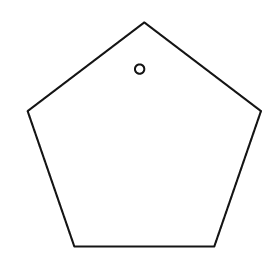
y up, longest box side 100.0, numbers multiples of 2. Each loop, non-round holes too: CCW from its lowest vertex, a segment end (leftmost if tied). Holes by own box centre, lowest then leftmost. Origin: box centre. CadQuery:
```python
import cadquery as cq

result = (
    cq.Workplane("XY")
    .moveTo(-30.0, -48.0)
    .lineTo(30.0, -48.0)
    .lineTo(50.0, 10.0)
    .lineTo(0.0, 48.0)
    .lineTo(-50.0, 10.0)
    .close()
    .moveTo(-2.0, 28.0)
    .circle(2.0)
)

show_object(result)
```